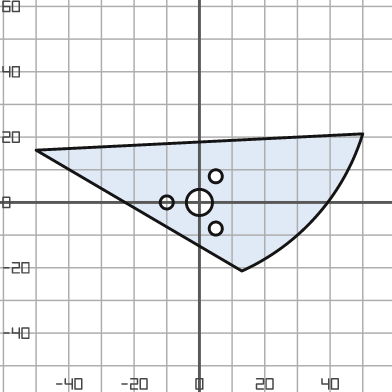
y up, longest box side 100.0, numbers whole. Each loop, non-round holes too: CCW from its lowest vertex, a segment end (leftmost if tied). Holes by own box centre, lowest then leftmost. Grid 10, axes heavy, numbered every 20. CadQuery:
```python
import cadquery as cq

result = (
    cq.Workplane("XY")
    .moveTo(13.0, -21.0)
    .threePointArc((36.0, -4.0), (50.0, 21.0))
    .lineTo(-50.0, 16.0)
    .close()
    .moveTo(5.0, -8.0)
    .circle(2.0)
    .moveTo(-10.0, 0.0)
    .circle(2.0)
    .moveTo(0.0, 0.0)
    .circle(4.0)
    .moveTo(5.0, 8.0)
    .circle(2.0)
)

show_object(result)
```